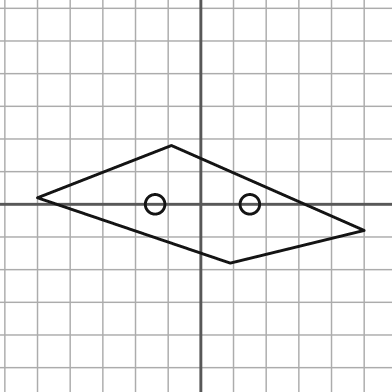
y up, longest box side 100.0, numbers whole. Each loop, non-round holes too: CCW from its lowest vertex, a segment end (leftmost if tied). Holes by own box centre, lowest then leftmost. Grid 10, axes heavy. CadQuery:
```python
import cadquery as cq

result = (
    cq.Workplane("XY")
    .moveTo(9.0, -18.0)
    .lineTo(50.0, -8.0)
    .lineTo(-9.0, 18.0)
    .lineTo(-50.0, 2.0)
    .close()
    .moveTo(-14.0, 0.0)
    .circle(3.0)
    .moveTo(15.0, 0.0)
    .circle(3.0)
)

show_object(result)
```